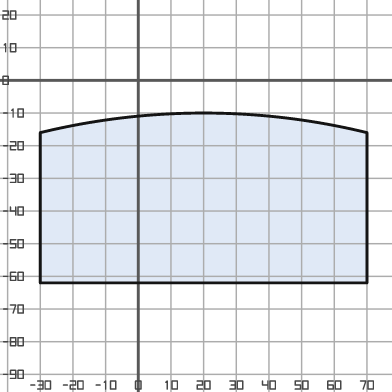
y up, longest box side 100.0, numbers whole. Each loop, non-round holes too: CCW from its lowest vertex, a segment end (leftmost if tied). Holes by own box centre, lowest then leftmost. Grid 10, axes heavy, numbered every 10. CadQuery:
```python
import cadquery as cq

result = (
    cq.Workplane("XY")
    .moveTo(-30.0, -62.0)
    .lineTo(70.0, -62.0)
    .lineTo(70.0, -16.0)
    .threePointArc((20.0, -10.0), (-30.0, -16.0))
    .close()
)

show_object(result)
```